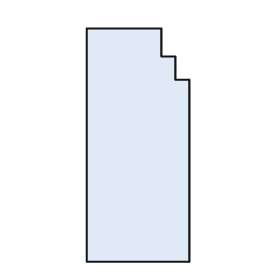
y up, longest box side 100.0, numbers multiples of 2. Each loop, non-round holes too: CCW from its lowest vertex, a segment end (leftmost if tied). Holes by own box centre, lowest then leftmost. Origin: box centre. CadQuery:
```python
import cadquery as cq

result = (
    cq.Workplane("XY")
    .moveTo(-22.0, -50.0)
    .lineTo(22.0, -50.0)
    .lineTo(22.0, 28.0)
    .lineTo(16.0, 28.0)
    .lineTo(16.0, 38.0)
    .lineTo(10.0, 38.0)
    .lineTo(10.0, 50.0)
    .lineTo(-22.0, 50.0)
    .close()
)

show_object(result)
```